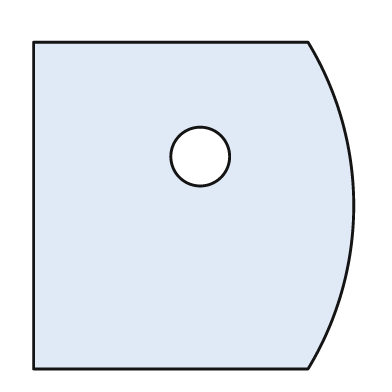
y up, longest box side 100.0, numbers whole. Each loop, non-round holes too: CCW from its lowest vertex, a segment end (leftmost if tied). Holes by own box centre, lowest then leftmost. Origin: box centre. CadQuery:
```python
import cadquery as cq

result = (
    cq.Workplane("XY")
    .moveTo(-49.0, -50.0)
    .lineTo(35.0, -50.0)
    .threePointArc((49.0, 0.0), (35.0, 50.0))
    .lineTo(-49.0, 50.0)
    .close()
    .moveTo(2.0, 15.0)
    .circle(9.0)
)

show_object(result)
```